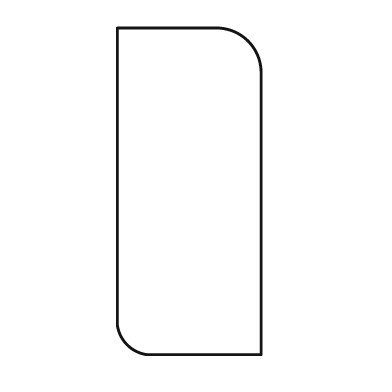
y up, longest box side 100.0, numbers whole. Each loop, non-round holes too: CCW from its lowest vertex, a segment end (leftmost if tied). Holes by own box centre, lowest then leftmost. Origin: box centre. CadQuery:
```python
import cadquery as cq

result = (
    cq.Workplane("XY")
    .moveTo(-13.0, -50.0)
    .lineTo(22.0, -50.0)
    .lineTo(22.0, 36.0)
    .threePointArc((18.0, 46.0), (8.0, 50.0))
    .lineTo(-22.0, 50.0)
    .lineTo(-22.0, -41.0)
    .threePointArc((-19.0, -47.0), (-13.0, -50.0))
    .close()
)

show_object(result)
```